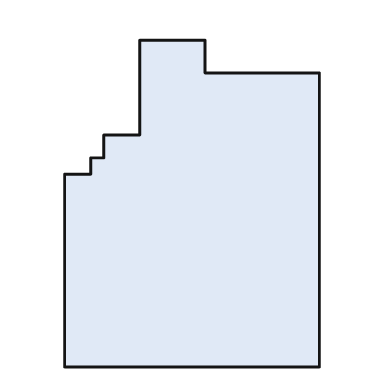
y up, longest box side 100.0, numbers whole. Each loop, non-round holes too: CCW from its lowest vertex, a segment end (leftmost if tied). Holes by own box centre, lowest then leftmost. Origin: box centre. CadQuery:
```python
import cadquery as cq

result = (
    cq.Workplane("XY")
    .moveTo(-39.0, -50.0)
    .lineTo(39.0, -50.0)
    .lineTo(39.0, 40.0)
    .lineTo(4.0, 40.0)
    .lineTo(4.0, 50.0)
    .lineTo(-16.0, 50.0)
    .lineTo(-16.0, 21.0)
    .lineTo(-27.0, 21.0)
    .lineTo(-27.0, 14.0)
    .lineTo(-31.0, 14.0)
    .lineTo(-31.0, 9.0)
    .lineTo(-39.0, 9.0)
    .close()
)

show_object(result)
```